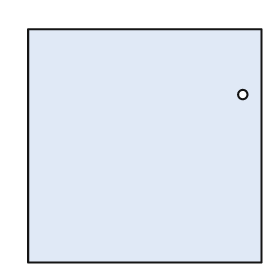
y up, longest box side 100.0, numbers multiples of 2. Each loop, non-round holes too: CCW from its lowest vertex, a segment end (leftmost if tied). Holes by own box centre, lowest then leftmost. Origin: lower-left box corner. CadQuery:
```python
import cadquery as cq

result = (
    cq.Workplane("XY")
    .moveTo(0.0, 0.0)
    .lineTo(100.0, 0.0)
    .lineTo(100.0, 100.0)
    .lineTo(0.0, 100.0)
    .close()
    .moveTo(92.0, 72.0)
    .circle(2.0)
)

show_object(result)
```